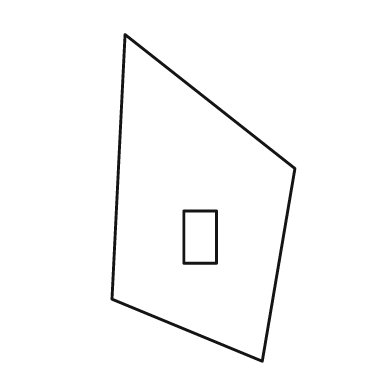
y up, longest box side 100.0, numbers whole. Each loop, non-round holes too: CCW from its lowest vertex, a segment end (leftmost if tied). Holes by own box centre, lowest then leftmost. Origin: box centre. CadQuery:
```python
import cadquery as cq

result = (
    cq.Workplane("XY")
    .moveTo(18.0, -50.0)
    .lineTo(28.0, 9.0)
    .lineTo(-24.0, 50.0)
    .lineTo(-28.0, -31.0)
    .close()
    .moveTo(-6.0, -20.0)
    .lineTo(4.0, -20.0)
    .lineTo(4.0, -4.0)
    .lineTo(-6.0, -4.0)
    .close()
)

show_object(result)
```